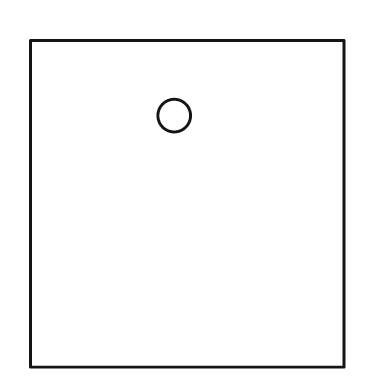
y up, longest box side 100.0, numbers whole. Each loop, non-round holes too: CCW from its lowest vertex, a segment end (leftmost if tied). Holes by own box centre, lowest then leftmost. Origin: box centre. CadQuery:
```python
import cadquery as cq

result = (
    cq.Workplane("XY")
    .moveTo(-48.0, -50.0)
    .lineTo(48.0, -50.0)
    .lineTo(48.0, 50.0)
    .lineTo(-48.0, 50.0)
    .close()
    .moveTo(-4.0, 27.0)
    .circle(5.0)
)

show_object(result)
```